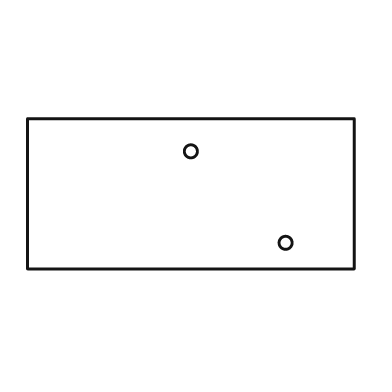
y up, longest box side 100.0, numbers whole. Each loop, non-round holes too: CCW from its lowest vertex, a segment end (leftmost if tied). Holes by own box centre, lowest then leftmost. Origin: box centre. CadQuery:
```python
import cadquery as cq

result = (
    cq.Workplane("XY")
    .moveTo(-50.0, -23.0)
    .lineTo(50.0, -23.0)
    .lineTo(50.0, 23.0)
    .lineTo(-50.0, 23.0)
    .close()
    .moveTo(29.0, -15.0)
    .circle(2.0)
    .moveTo(0.0, 13.0)
    .circle(2.0)
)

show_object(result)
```